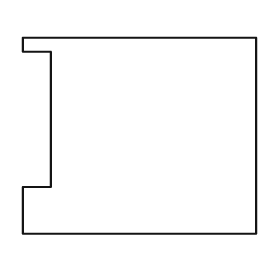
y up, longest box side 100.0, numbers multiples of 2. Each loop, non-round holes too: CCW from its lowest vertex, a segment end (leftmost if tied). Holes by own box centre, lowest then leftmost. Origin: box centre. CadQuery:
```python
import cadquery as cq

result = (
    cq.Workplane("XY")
    .moveTo(-50.0, -42.0)
    .lineTo(50.0, -42.0)
    .lineTo(50.0, 42.0)
    .lineTo(-50.0, 42.0)
    .lineTo(-50.0, 36.0)
    .lineTo(-38.0, 36.0)
    .lineTo(-38.0, -22.0)
    .lineTo(-50.0, -22.0)
    .close()
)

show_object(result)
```